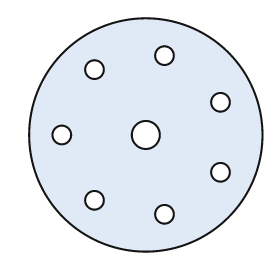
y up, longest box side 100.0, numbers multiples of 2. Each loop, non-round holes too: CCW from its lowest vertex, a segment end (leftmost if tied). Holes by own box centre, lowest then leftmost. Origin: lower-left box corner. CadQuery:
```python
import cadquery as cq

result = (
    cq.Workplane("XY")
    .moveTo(50.0, 50.0)
    .circle(50.0)
    .moveTo(58.0, 16.0)
    .circle(4.0)
    .moveTo(28.0, 22.0)
    .circle(4.0)
    .moveTo(82.0, 34.0)
    .circle(4.0)
    .moveTo(14.0, 50.0)
    .circle(4.0)
    .moveTo(50.0, 50.0)
    .circle(6.0)
    .moveTo(82.0, 64.0)
    .circle(4.0)
    .moveTo(28.0, 78.0)
    .circle(4.0)
    .moveTo(58.0, 84.0)
    .circle(4.0)
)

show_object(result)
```